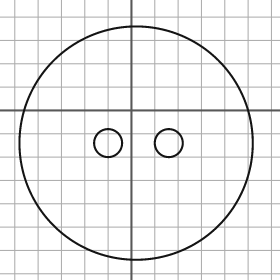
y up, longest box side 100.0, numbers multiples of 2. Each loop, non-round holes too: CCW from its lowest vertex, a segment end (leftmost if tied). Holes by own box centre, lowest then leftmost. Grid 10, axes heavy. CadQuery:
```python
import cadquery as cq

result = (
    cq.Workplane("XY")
    .moveTo(2.0, -14.0)
    .circle(50.0)
    .moveTo(-10.0, -14.0)
    .circle(6.0)
    .moveTo(16.0, -14.0)
    .circle(6.0)
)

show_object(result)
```